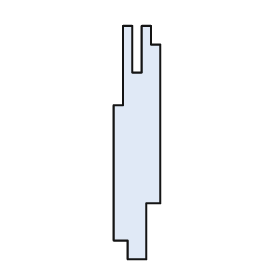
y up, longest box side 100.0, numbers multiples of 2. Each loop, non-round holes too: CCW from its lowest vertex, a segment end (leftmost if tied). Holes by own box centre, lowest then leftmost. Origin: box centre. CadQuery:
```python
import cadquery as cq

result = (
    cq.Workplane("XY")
    .moveTo(-4.0, -50.0)
    .lineTo(4.0, -50.0)
    .lineTo(4.0, -26.0)
    .lineTo(10.0, -26.0)
    .lineTo(10.0, 42.0)
    .lineTo(6.0, 42.0)
    .lineTo(6.0, 50.0)
    .lineTo(2.0, 50.0)
    .lineTo(2.0, 30.0)
    .lineTo(-2.0, 30.0)
    .lineTo(-2.0, 50.0)
    .lineTo(-6.0, 50.0)
    .lineTo(-6.0, 16.0)
    .lineTo(-10.0, 16.0)
    .lineTo(-10.0, -42.0)
    .lineTo(-4.0, -42.0)
    .close()
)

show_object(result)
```